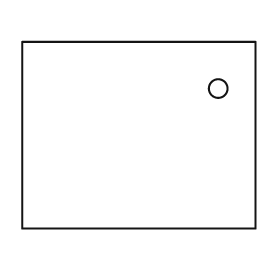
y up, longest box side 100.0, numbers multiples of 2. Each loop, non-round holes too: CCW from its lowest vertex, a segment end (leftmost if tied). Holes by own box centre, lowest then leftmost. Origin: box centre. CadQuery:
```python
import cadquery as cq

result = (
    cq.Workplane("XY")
    .moveTo(-50.0, -40.0)
    .lineTo(50.0, -40.0)
    .lineTo(50.0, 40.0)
    .lineTo(-50.0, 40.0)
    .close()
    .moveTo(34.0, 20.0)
    .circle(4.0)
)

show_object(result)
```